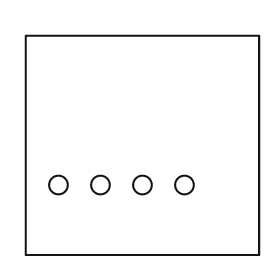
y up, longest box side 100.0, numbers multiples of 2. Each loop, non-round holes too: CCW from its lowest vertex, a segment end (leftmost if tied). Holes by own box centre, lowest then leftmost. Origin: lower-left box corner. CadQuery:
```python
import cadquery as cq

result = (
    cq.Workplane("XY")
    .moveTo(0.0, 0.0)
    .lineTo(100.0, 0.0)
    .lineTo(100.0, 94.0)
    .lineTo(0.0, 94.0)
    .close()
    .moveTo(14.0, 30.0)
    .circle(4.0)
    .moveTo(32.0, 30.0)
    .circle(4.0)
    .moveTo(50.0, 30.0)
    .circle(4.0)
    .moveTo(68.0, 30.0)
    .circle(4.0)
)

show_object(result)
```